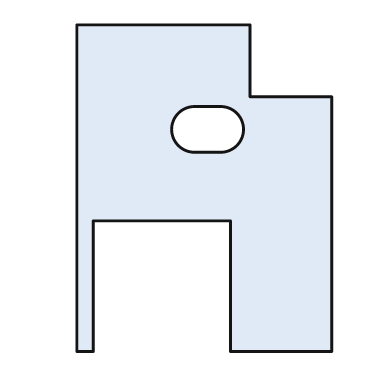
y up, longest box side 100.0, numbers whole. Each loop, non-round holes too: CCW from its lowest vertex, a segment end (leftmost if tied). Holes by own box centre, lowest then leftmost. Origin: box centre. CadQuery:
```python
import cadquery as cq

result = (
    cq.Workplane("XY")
    .moveTo(-39.0, -50.0)
    .lineTo(-34.0, -50.0)
    .lineTo(-34.0, -10.0)
    .lineTo(8.0, -10.0)
    .lineTo(8.0, -50.0)
    .lineTo(39.0, -50.0)
    .lineTo(39.0, 28.0)
    .lineTo(14.0, 28.0)
    .lineTo(14.0, 50.0)
    .lineTo(-39.0, 50.0)
    .close()
    .moveTo(-3.0, 11.0)
    .lineTo(5.0, 11.0)
    .threePointArc((12.0, 18.0), (5.0, 25.0))
    .lineTo(-3.0, 25.0)
    .threePointArc((-10.0, 18.0), (-3.0, 11.0))
    .close()
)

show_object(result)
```